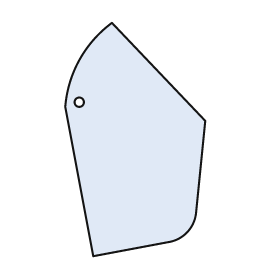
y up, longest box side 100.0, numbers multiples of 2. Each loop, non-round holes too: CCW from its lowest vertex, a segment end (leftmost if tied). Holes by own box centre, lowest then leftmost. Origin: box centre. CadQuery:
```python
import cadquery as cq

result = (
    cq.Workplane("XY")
    .moveTo(-18.0, -50.0)
    .lineTo(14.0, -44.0)
    .threePointArc((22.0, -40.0), (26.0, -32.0))
    .lineTo(30.0, 8.0)
    .lineTo(-10.0, 50.0)
    .threePointArc((-24.0, 34.0), (-30.0, 14.0))
    .close()
    .moveTo(-24.0, 16.0)
    .circle(2.0)
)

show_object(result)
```